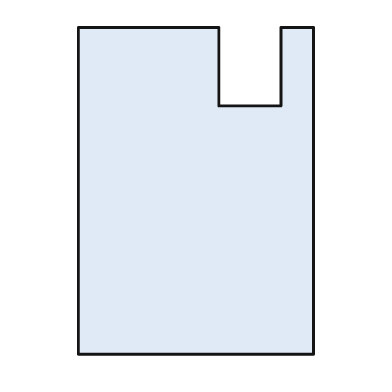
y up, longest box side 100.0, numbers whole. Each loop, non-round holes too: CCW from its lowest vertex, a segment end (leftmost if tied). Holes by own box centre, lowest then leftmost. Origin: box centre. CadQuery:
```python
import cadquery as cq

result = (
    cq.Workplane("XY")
    .moveTo(-36.0, -50.0)
    .lineTo(36.0, -50.0)
    .lineTo(36.0, 50.0)
    .lineTo(26.0, 50.0)
    .lineTo(26.0, 26.0)
    .lineTo(7.0, 26.0)
    .lineTo(7.0, 50.0)
    .lineTo(-36.0, 50.0)
    .close()
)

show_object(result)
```